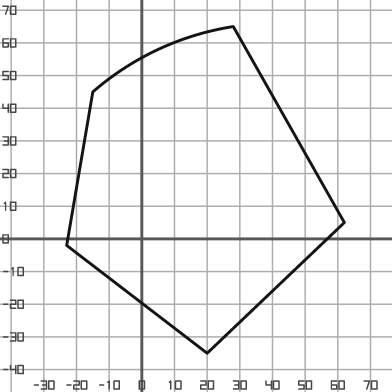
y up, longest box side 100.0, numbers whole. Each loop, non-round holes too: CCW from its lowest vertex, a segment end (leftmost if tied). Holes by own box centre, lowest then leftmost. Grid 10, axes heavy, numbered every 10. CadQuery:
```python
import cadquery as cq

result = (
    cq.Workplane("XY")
    .moveTo(20.0, -35.0)
    .lineTo(62.0, 5.0)
    .lineTo(28.0, 65.0)
    .threePointArc((5.0, 58.0), (-15.0, 45.0))
    .lineTo(-23.0, -2.0)
    .close()
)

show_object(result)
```